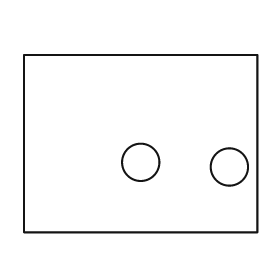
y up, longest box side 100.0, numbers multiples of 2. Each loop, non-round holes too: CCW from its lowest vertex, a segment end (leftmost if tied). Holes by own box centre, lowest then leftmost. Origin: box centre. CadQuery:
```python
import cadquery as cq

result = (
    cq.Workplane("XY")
    .moveTo(-50.0, -38.0)
    .lineTo(50.0, -38.0)
    .lineTo(50.0, 38.0)
    .lineTo(-50.0, 38.0)
    .close()
    .moveTo(38.0, -10.0)
    .circle(8.0)
    .moveTo(0.0, -8.0)
    .circle(8.0)
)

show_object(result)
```